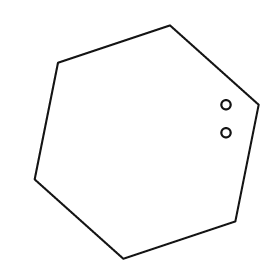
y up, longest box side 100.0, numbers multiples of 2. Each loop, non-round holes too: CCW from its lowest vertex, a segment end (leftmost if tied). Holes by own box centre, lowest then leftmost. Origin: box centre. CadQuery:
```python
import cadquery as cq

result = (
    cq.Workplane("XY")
    .moveTo(-10.0, -50.0)
    .lineTo(38.0, -34.0)
    .lineTo(48.0, 16.0)
    .lineTo(10.0, 50.0)
    .lineTo(-38.0, 34.0)
    .lineTo(-48.0, -16.0)
    .close()
    .moveTo(34.0, 4.0)
    .circle(2.0)
    .moveTo(34.0, 16.0)
    .circle(2.0)
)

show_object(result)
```